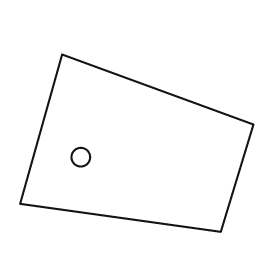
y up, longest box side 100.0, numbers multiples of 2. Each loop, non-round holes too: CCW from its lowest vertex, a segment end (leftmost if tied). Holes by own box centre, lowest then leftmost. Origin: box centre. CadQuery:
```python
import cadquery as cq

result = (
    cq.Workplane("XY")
    .moveTo(36.0, -38.0)
    .lineTo(50.0, 8.0)
    .lineTo(-32.0, 38.0)
    .lineTo(-50.0, -26.0)
    .close()
    .moveTo(-24.0, -6.0)
    .circle(4.0)
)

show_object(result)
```